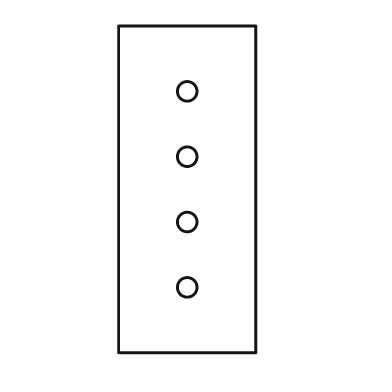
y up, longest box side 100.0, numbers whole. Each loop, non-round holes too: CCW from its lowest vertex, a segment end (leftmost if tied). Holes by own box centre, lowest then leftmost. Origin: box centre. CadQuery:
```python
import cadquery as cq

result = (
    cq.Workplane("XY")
    .moveTo(-21.0, -50.0)
    .lineTo(21.0, -50.0)
    .lineTo(21.0, 50.0)
    .lineTo(-21.0, 50.0)
    .close()
    .moveTo(0.0, -30.0)
    .circle(3.0)
    .moveTo(0.0, -10.0)
    .circle(3.0)
    .moveTo(0.0, 10.0)
    .circle(3.0)
    .moveTo(0.0, 30.0)
    .circle(3.0)
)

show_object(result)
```